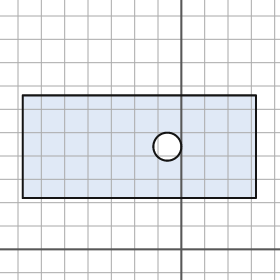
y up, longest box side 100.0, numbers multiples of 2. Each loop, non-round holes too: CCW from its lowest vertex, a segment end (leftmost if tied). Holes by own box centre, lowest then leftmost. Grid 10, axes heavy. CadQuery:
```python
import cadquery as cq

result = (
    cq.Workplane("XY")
    .moveTo(-68.0, 22.0)
    .lineTo(32.0, 22.0)
    .lineTo(32.0, 66.0)
    .lineTo(-68.0, 66.0)
    .close()
    .moveTo(-6.0, 44.0)
    .circle(6.0)
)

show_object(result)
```